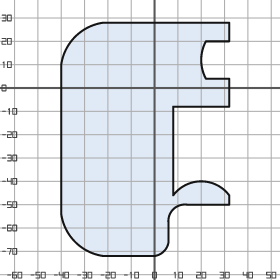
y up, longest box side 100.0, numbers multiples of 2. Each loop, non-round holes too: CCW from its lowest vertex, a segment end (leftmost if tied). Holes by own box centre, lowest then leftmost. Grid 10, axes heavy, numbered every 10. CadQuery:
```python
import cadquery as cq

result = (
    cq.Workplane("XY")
    .moveTo(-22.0, -72.0)
    .lineTo(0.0, -72.0)
    .threePointArc((4.0, -70.0), (6.0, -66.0))
    .lineTo(6.0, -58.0)
    .threePointArc((8.0, -52.0), (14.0, -50.0))
    .lineTo(32.0, -50.0)
    .lineTo(32.0, -46.0)
    .threePointArc((20.0, -40.0), (8.0, -46.0))
    .lineTo(8.0, -8.0)
    .lineTo(32.0, -8.0)
    .lineTo(32.0, 4.0)
    .lineTo(22.0, 4.0)
    .threePointArc((20.0, 12.0), (22.0, 20.0))
    .lineTo(32.0, 20.0)
    .lineTo(32.0, 28.0)
    .lineTo(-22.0, 28.0)
    .threePointArc((-34.0, 22.0), (-40.0, 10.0))
    .lineTo(-40.0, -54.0)
    .threePointArc((-34.0, -66.0), (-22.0, -72.0))
    .close()
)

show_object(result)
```